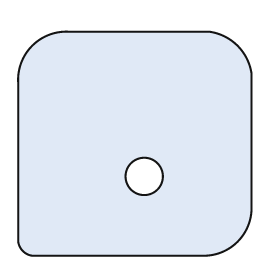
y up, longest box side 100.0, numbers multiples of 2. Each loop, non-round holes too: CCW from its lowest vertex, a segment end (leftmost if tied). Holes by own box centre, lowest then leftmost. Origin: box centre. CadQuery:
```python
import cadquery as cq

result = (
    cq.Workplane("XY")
    .moveTo(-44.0, -48.0)
    .lineTo(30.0, -48.0)
    .threePointArc((44.0, -42.0), (50.0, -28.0))
    .lineTo(50.0, 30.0)
    .threePointArc((44.0, 42.0), (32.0, 48.0))
    .lineTo(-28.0, 48.0)
    .threePointArc((-44.0, 42.0), (-50.0, 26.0))
    .lineTo(-50.0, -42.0)
    .threePointArc((-48.0, -46.0), (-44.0, -48.0))
    .close()
    .moveTo(4.0, -14.0)
    .circle(8.0)
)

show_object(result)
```